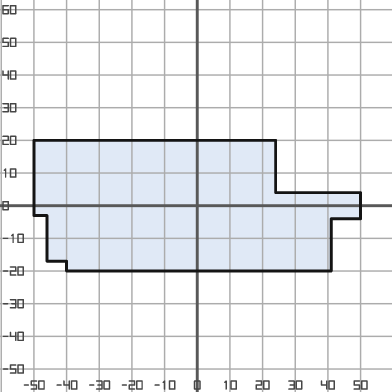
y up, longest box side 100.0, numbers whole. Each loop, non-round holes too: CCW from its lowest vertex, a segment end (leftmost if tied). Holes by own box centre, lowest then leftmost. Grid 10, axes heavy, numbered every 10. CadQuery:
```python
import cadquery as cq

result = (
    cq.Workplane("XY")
    .moveTo(-40.0, -20.0)
    .lineTo(41.0, -20.0)
    .lineTo(41.0, -4.0)
    .lineTo(50.0, -4.0)
    .lineTo(50.0, 4.0)
    .lineTo(24.0, 4.0)
    .lineTo(24.0, 20.0)
    .lineTo(-50.0, 20.0)
    .lineTo(-50.0, -3.0)
    .lineTo(-46.0, -3.0)
    .lineTo(-46.0, -17.0)
    .lineTo(-40.0, -17.0)
    .close()
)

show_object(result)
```